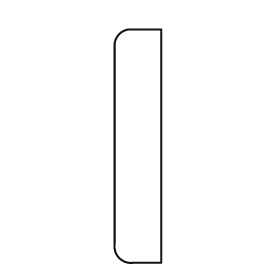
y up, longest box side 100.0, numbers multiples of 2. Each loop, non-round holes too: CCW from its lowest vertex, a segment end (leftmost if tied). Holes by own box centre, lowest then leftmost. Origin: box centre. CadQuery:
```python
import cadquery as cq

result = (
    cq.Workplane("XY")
    .moveTo(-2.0, -50.0)
    .lineTo(10.0, -50.0)
    .lineTo(10.0, 50.0)
    .lineTo(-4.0, 50.0)
    .threePointArc((-8.0, 48.0), (-10.0, 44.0))
    .lineTo(-10.0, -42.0)
    .threePointArc((-8.0, -48.0), (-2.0, -50.0))
    .close()
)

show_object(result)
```